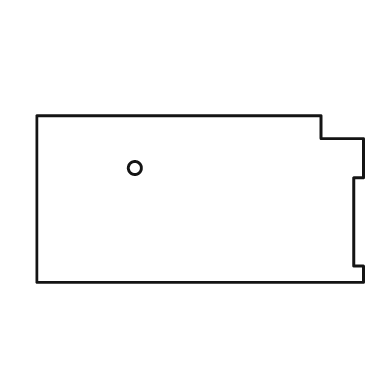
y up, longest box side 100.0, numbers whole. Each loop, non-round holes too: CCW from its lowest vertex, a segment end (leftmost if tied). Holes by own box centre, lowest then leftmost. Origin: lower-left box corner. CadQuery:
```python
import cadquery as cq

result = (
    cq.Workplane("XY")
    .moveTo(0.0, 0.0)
    .lineTo(100.0, 0.0)
    .lineTo(100.0, 5.0)
    .lineTo(97.0, 5.0)
    .lineTo(97.0, 32.0)
    .lineTo(100.0, 32.0)
    .lineTo(100.0, 44.0)
    .lineTo(87.0, 44.0)
    .lineTo(87.0, 51.0)
    .lineTo(0.0, 51.0)
    .close()
    .moveTo(30.0, 35.0)
    .circle(2.0)
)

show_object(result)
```